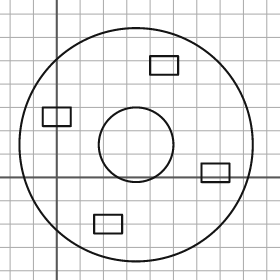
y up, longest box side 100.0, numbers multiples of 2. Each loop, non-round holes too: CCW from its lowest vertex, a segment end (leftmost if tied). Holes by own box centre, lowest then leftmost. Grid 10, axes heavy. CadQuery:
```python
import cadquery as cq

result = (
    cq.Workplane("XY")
    .moveTo(34.0, 14.0)
    .circle(50.0)
    .moveTo(16.0, -24.0)
    .lineTo(28.0, -24.0)
    .lineTo(28.0, -16.0)
    .lineTo(16.0, -16.0)
    .close()
    .moveTo(62.0, -2.0)
    .lineTo(74.0, -2.0)
    .lineTo(74.0, 6.0)
    .lineTo(62.0, 6.0)
    .close()
    .moveTo(34.0, 14.0)
    .circle(16.0)
    .moveTo(-6.0, 22.0)
    .lineTo(6.0, 22.0)
    .lineTo(6.0, 30.0)
    .lineTo(-6.0, 30.0)
    .close()
    .moveTo(40.0, 44.0)
    .lineTo(52.0, 44.0)
    .lineTo(52.0, 52.0)
    .lineTo(40.0, 52.0)
    .close()
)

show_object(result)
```